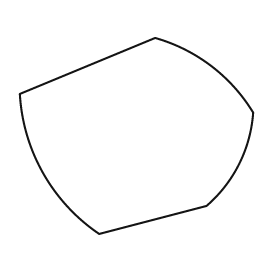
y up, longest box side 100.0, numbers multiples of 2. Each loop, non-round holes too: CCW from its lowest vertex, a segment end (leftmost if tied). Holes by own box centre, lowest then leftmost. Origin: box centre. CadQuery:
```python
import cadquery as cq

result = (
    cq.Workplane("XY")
    .moveTo(-16.0, -42.0)
    .lineTo(30.0, -30.0)
    .threePointArc((44.0, -12.0), (50.0, 10.0))
    .threePointArc((32.0, 30.0), (8.0, 42.0))
    .lineTo(-50.0, 18.0)
    .threePointArc((-40.0, -16.0), (-16.0, -42.0))
    .close()
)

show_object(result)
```